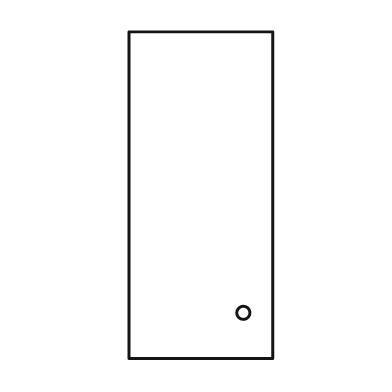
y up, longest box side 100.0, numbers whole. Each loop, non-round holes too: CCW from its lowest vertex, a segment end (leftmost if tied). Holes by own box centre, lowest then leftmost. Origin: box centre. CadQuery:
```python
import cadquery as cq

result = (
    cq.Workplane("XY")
    .moveTo(-22.0, -50.0)
    .lineTo(22.0, -50.0)
    .lineTo(22.0, 50.0)
    .lineTo(-22.0, 50.0)
    .close()
    .moveTo(13.0, -36.0)
    .circle(2.0)
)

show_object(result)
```